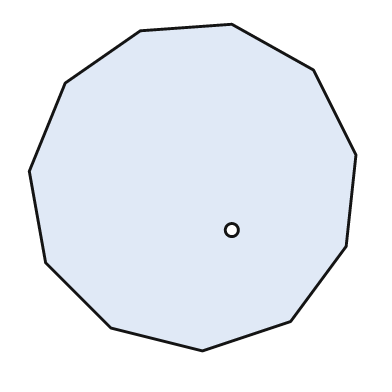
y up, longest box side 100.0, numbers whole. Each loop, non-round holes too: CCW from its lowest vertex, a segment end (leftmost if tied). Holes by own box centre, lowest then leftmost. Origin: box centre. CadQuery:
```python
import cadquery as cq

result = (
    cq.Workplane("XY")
    .moveTo(3.0, -50.0)
    .lineTo(30.0, -41.0)
    .lineTo(47.0, -18.0)
    .lineTo(50.0, 10.0)
    .lineTo(37.0, 36.0)
    .lineTo(12.0, 50.0)
    .lineTo(-16.0, 48.0)
    .lineTo(-39.0, 32.0)
    .lineTo(-50.0, 5.0)
    .lineTo(-45.0, -23.0)
    .lineTo(-25.0, -43.0)
    .close()
    .moveTo(12.0, -13.0)
    .circle(2.0)
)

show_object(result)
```